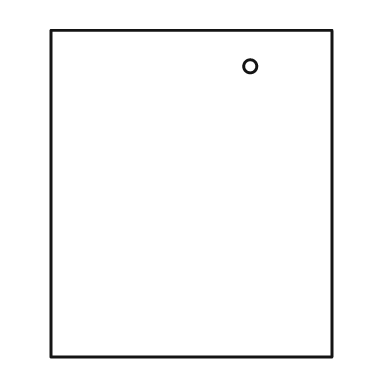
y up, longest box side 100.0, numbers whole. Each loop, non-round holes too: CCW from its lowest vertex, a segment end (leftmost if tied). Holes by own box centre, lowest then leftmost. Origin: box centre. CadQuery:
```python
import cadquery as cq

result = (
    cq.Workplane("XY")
    .moveTo(-43.0, -50.0)
    .lineTo(43.0, -50.0)
    .lineTo(43.0, 50.0)
    .lineTo(-43.0, 50.0)
    .close()
    .moveTo(18.0, 39.0)
    .circle(2.0)
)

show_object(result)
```